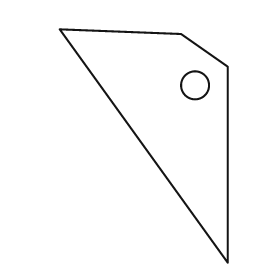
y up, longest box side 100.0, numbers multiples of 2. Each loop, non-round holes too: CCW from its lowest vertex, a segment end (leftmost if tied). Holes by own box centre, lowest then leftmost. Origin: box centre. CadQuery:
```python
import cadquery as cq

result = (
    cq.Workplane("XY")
    .moveTo(36.0, -50.0)
    .lineTo(36.0, 34.0)
    .lineTo(16.0, 48.0)
    .lineTo(-36.0, 50.0)
    .close()
    .moveTo(22.0, 26.0)
    .circle(6.0)
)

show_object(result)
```